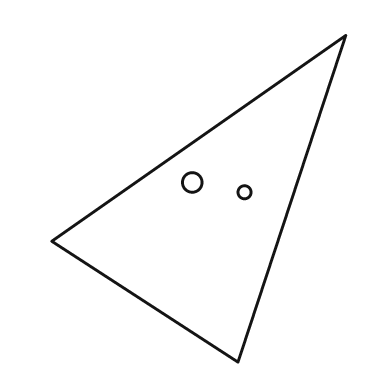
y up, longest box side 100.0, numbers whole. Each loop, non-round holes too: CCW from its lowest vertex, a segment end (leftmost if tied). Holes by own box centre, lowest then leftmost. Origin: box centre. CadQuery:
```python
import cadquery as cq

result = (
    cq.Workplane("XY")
    .moveTo(12.0, -50.0)
    .lineTo(45.0, 50.0)
    .lineTo(-45.0, -13.0)
    .close()
    .moveTo(14.0, 2.0)
    .circle(2.0)
    .moveTo(-2.0, 5.0)
    .circle(3.0)
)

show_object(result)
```